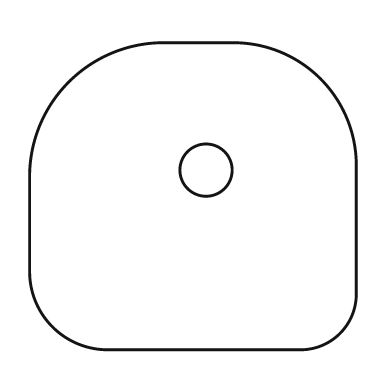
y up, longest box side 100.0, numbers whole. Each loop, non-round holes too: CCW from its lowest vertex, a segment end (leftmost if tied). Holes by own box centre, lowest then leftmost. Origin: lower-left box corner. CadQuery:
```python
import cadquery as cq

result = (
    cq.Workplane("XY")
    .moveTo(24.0, 0.0)
    .lineTo(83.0, 0.0)
    .threePointArc((95.0, 5.0), (100.0, 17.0))
    .lineTo(100.0, 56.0)
    .threePointArc((89.0, 83.0), (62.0, 94.0))
    .lineTo(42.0, 94.0)
    .threePointArc((12.0, 82.0), (0.0, 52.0))
    .lineTo(0.0, 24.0)
    .threePointArc((7.0, 7.0), (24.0, 0.0))
    .close()
    .moveTo(54.0, 55.0)
    .circle(8.0)
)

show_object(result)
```